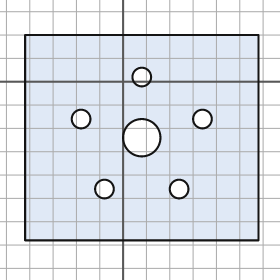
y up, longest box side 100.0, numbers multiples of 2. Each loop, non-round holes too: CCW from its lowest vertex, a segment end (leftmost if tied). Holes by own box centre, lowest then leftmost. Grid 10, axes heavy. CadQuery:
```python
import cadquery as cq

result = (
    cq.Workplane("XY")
    .moveTo(-42.0, -68.0)
    .lineTo(58.0, -68.0)
    .lineTo(58.0, 20.0)
    .lineTo(-42.0, 20.0)
    .close()
    .moveTo(-8.0, -46.0)
    .circle(4.0)
    .moveTo(24.0, -46.0)
    .circle(4.0)
    .moveTo(8.0, -24.0)
    .circle(8.0)
    .moveTo(-18.0, -16.0)
    .circle(4.0)
    .moveTo(34.0, -16.0)
    .circle(4.0)
    .moveTo(8.0, 2.0)
    .circle(4.0)
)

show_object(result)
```